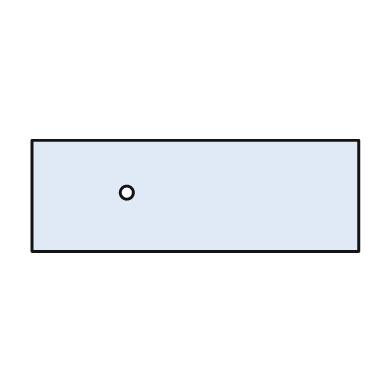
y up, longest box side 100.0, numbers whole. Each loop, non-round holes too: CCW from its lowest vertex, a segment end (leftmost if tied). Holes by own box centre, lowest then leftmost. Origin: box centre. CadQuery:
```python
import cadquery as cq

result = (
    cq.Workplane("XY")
    .moveTo(-50.0, -17.0)
    .lineTo(50.0, -17.0)
    .lineTo(50.0, 17.0)
    .lineTo(-50.0, 17.0)
    .close()
    .moveTo(-21.0, 1.0)
    .circle(2.0)
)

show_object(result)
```